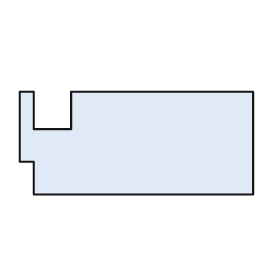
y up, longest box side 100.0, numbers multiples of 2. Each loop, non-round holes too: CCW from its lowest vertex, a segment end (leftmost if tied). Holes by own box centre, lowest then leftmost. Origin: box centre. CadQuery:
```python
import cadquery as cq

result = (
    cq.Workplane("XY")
    .moveTo(-44.0, -22.0)
    .lineTo(50.0, -22.0)
    .lineTo(50.0, 22.0)
    .lineTo(-28.0, 22.0)
    .lineTo(-28.0, 6.0)
    .lineTo(-44.0, 6.0)
    .lineTo(-44.0, 22.0)
    .lineTo(-50.0, 22.0)
    .lineTo(-50.0, -8.0)
    .lineTo(-44.0, -8.0)
    .close()
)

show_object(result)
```